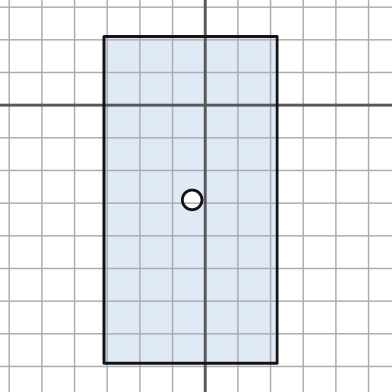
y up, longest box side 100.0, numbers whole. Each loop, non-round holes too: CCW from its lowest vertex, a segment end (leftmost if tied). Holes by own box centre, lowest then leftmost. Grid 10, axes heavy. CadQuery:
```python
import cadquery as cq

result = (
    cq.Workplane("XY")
    .moveTo(-31.0, -79.0)
    .lineTo(22.0, -79.0)
    .lineTo(22.0, 21.0)
    .lineTo(-31.0, 21.0)
    .close()
    .moveTo(-4.0, -29.0)
    .circle(3.0)
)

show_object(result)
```